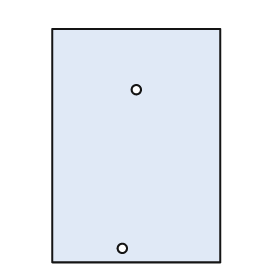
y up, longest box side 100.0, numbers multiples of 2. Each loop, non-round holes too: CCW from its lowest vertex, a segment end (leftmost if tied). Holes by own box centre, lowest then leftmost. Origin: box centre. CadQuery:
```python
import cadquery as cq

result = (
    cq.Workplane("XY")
    .moveTo(-36.0, -50.0)
    .lineTo(36.0, -50.0)
    .lineTo(36.0, 50.0)
    .lineTo(-36.0, 50.0)
    .close()
    .moveTo(-6.0, -44.0)
    .circle(2.0)
    .moveTo(0.0, 24.0)
    .circle(2.0)
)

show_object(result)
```